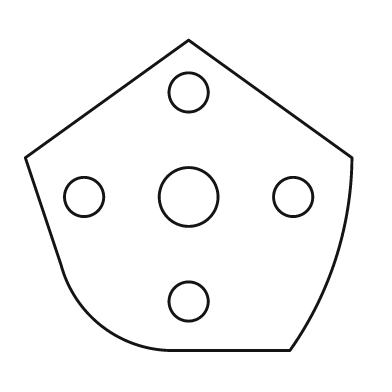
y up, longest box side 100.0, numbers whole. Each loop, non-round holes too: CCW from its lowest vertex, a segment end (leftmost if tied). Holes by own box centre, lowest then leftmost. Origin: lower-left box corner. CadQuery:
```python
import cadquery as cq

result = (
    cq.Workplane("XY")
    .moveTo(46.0, 0.0)
    .lineTo(81.0, 0.0)
    .threePointArc((95.0, 28.0), (100.0, 59.0))
    .lineTo(50.0, 95.0)
    .lineTo(0.0, 59.0)
    .lineTo(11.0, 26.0)
    .threePointArc((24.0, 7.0), (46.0, 0.0))
    .close()
    .moveTo(50.0, 15.0)
    .circle(6.0)
    .moveTo(18.0, 47.0)
    .circle(6.0)
    .moveTo(50.0, 47.0)
    .circle(9.0)
    .moveTo(82.0, 47.0)
    .circle(6.0)
    .moveTo(50.0, 79.0)
    .circle(6.0)
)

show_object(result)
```